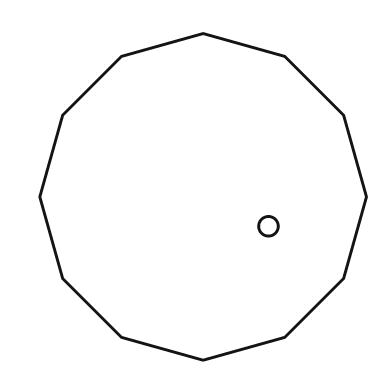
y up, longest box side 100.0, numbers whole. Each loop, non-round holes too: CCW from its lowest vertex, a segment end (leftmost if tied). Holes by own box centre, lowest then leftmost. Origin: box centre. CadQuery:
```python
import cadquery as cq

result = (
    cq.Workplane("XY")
    .moveTo(0.0, -50.0)
    .lineTo(25.0, -43.0)
    .lineTo(43.0, -25.0)
    .lineTo(50.0, 0.0)
    .lineTo(43.0, 25.0)
    .lineTo(25.0, 43.0)
    .lineTo(0.0, 50.0)
    .lineTo(-25.0, 43.0)
    .lineTo(-43.0, 25.0)
    .lineTo(-50.0, 0.0)
    .lineTo(-43.0, -25.0)
    .lineTo(-25.0, -43.0)
    .close()
    .moveTo(20.0, -9.0)
    .circle(3.0)
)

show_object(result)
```